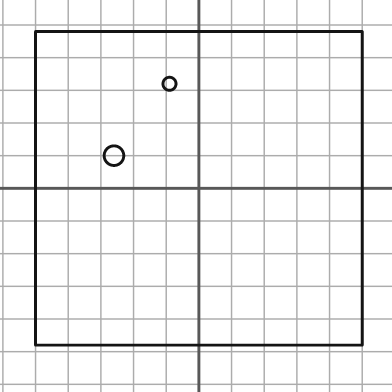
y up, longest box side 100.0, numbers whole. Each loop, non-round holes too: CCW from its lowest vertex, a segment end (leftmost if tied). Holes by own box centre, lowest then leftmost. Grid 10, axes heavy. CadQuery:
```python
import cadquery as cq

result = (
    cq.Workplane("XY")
    .moveTo(-50.0, -48.0)
    .lineTo(50.0, -48.0)
    .lineTo(50.0, 48.0)
    .lineTo(-50.0, 48.0)
    .close()
    .moveTo(-26.0, 10.0)
    .circle(3.0)
    .moveTo(-9.0, 32.0)
    .circle(2.0)
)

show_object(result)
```